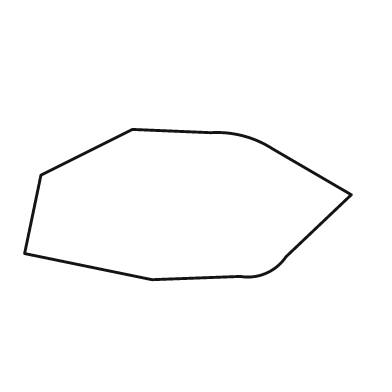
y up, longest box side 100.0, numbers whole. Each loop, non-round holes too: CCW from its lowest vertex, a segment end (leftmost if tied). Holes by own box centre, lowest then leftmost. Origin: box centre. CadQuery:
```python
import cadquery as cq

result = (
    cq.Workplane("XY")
    .moveTo(-11.0, -23.0)
    .lineTo(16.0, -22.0)
    .threePointArc((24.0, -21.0), (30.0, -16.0))
    .lineTo(50.0, 3.0)
    .lineTo(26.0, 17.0)
    .threePointArc((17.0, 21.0), (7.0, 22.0))
    .lineTo(-17.0, 23.0)
    .lineTo(-45.0, 9.0)
    .lineTo(-50.0, -15.0)
    .close()
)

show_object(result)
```